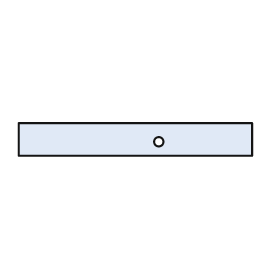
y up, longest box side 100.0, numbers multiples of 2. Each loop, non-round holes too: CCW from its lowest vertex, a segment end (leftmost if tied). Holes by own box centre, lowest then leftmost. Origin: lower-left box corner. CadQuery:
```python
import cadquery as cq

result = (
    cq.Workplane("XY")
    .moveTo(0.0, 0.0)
    .lineTo(100.0, 0.0)
    .lineTo(100.0, 14.0)
    .lineTo(0.0, 14.0)
    .close()
    .moveTo(60.0, 6.0)
    .circle(2.0)
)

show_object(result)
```